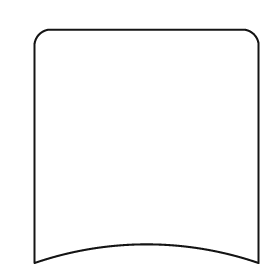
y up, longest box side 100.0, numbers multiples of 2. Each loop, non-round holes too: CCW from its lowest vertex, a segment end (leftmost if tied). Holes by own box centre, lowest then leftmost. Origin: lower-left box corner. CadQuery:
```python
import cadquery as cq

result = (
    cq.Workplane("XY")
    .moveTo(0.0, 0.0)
    .threePointArc((48.0, 8.0), (96.0, 0.0))
    .lineTo(96.0, 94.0)
    .threePointArc((94.0, 98.0), (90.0, 100.0))
    .lineTo(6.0, 100.0)
    .threePointArc((2.0, 98.0), (0.0, 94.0))
    .close()
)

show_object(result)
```